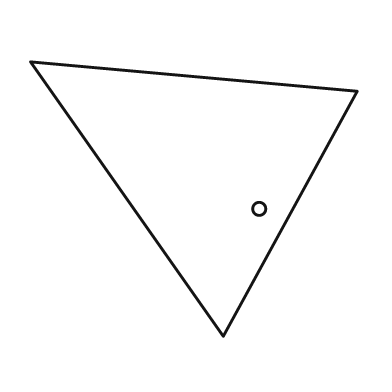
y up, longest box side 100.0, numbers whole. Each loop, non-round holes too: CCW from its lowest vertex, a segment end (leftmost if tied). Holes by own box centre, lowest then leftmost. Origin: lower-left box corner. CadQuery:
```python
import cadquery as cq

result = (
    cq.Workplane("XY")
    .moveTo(59.0, 0.0)
    .lineTo(100.0, 75.0)
    .lineTo(0.0, 84.0)
    .close()
    .moveTo(70.0, 39.0)
    .circle(2.0)
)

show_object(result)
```